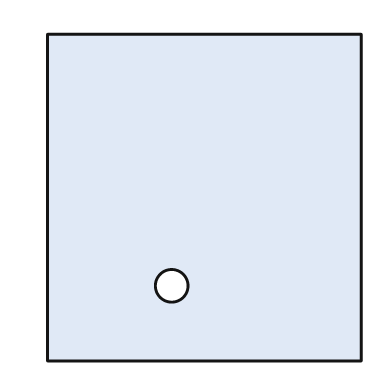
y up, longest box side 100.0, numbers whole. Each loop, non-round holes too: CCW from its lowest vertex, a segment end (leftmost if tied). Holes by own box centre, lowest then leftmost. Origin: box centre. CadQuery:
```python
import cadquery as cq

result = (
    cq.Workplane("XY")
    .moveTo(-48.0, -50.0)
    .lineTo(48.0, -50.0)
    .lineTo(48.0, 50.0)
    .lineTo(-48.0, 50.0)
    .close()
    .moveTo(-10.0, -27.0)
    .circle(5.0)
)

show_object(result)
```